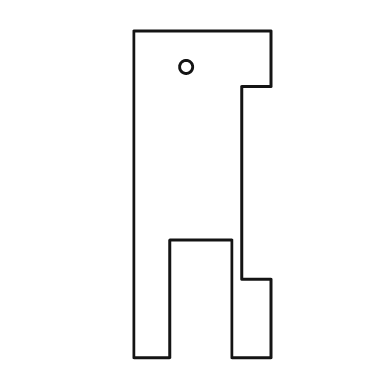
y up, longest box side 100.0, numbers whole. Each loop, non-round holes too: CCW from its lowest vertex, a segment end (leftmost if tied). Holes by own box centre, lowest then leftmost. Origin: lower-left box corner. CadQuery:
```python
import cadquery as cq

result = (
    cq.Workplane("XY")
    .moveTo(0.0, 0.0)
    .lineTo(11.0, 0.0)
    .lineTo(11.0, 36.0)
    .lineTo(30.0, 36.0)
    .lineTo(30.0, 0.0)
    .lineTo(42.0, 0.0)
    .lineTo(42.0, 24.0)
    .lineTo(33.0, 24.0)
    .lineTo(33.0, 83.0)
    .lineTo(42.0, 83.0)
    .lineTo(42.0, 100.0)
    .lineTo(0.0, 100.0)
    .close()
    .moveTo(16.0, 89.0)
    .circle(2.0)
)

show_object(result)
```